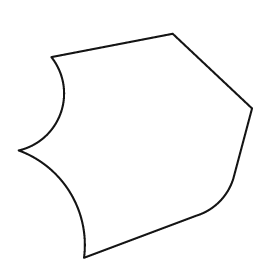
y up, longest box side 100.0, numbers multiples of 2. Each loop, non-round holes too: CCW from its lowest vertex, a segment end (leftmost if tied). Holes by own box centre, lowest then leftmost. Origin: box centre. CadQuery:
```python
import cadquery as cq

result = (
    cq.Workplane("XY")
    .moveTo(-22.0, -48.0)
    .lineTo(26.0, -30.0)
    .threePointArc((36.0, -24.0), (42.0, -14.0))
    .lineTo(50.0, 16.0)
    .lineTo(16.0, 48.0)
    .lineTo(-36.0, 38.0)
    .threePointArc((-32.0, 14.0), (-50.0, -2.0))
    .threePointArc((-28.0, -20.0), (-22.0, -48.0))
    .close()
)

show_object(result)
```